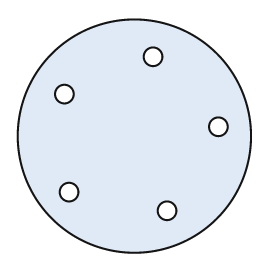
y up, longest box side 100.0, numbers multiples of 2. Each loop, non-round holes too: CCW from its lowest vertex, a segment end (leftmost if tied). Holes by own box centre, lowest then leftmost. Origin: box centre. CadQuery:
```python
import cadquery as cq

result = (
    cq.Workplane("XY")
    .moveTo(0.0, 0.0)
    .circle(50.0)
    .moveTo(14.0, -32.0)
    .circle(4.0)
    .moveTo(-28.0, -24.0)
    .circle(4.0)
    .moveTo(36.0, 4.0)
    .circle(4.0)
    .moveTo(-30.0, 18.0)
    .circle(4.0)
    .moveTo(8.0, 34.0)
    .circle(4.0)
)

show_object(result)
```